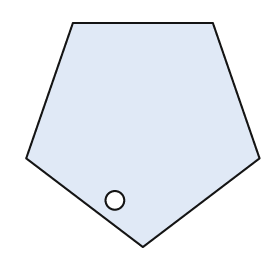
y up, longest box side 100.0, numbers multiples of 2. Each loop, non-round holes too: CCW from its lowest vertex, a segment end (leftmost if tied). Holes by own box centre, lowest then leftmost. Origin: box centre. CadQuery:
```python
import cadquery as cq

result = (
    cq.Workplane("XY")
    .moveTo(0.0, -48.0)
    .lineTo(50.0, -10.0)
    .lineTo(30.0, 48.0)
    .lineTo(-30.0, 48.0)
    .lineTo(-50.0, -10.0)
    .close()
    .moveTo(-12.0, -28.0)
    .circle(4.0)
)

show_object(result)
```